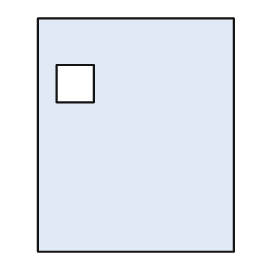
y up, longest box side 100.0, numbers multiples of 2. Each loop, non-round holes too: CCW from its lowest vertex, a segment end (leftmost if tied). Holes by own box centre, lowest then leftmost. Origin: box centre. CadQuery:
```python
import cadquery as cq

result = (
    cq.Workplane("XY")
    .moveTo(-42.0, -50.0)
    .lineTo(42.0, -50.0)
    .lineTo(42.0, 50.0)
    .lineTo(-42.0, 50.0)
    .close()
    .moveTo(-34.0, 14.0)
    .lineTo(-18.0, 14.0)
    .lineTo(-18.0, 30.0)
    .lineTo(-34.0, 30.0)
    .close()
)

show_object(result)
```